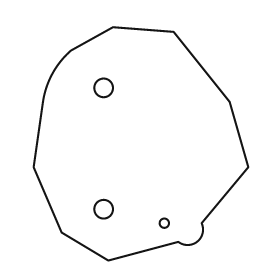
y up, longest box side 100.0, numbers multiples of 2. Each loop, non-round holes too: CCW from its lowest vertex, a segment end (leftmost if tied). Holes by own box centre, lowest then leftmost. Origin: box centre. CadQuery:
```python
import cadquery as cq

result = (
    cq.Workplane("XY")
    .moveTo(-14.0, -50.0)
    .lineTo(16.0, -42.0)
    .threePointArc((24.0, -42.0), (26.0, -34.0))
    .lineTo(46.0, -10.0)
    .lineTo(38.0, 18.0)
    .lineTo(14.0, 48.0)
    .lineTo(-12.0, 50.0)
    .lineTo(-30.0, 40.0)
    .threePointArc((-38.0, 30.0), (-42.0, 18.0))
    .lineTo(-46.0, -10.0)
    .lineTo(-34.0, -38.0)
    .close()
    .moveTo(10.0, -34.0)
    .circle(2.0)
    .moveTo(-16.0, -28.0)
    .circle(4.0)
    .moveTo(-16.0, 24.0)
    .circle(4.0)
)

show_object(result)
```